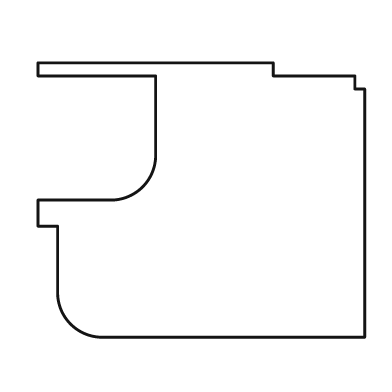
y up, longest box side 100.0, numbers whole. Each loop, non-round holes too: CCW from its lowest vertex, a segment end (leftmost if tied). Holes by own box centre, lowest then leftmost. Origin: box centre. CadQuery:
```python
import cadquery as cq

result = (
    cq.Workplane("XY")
    .moveTo(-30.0, -42.0)
    .lineTo(50.0, -42.0)
    .lineTo(50.0, 34.0)
    .lineTo(47.0, 34.0)
    .lineTo(47.0, 38.0)
    .lineTo(22.0, 38.0)
    .lineTo(22.0, 42.0)
    .lineTo(-50.0, 42.0)
    .lineTo(-50.0, 38.0)
    .lineTo(-14.0, 38.0)
    .lineTo(-14.0, 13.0)
    .threePointArc((-18.0, 4.0), (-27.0, 0.0))
    .lineTo(-50.0, 0.0)
    .lineTo(-50.0, -8.0)
    .lineTo(-44.0, -8.0)
    .lineTo(-44.0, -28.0)
    .threePointArc((-40.0, -38.0), (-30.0, -42.0))
    .close()
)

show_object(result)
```